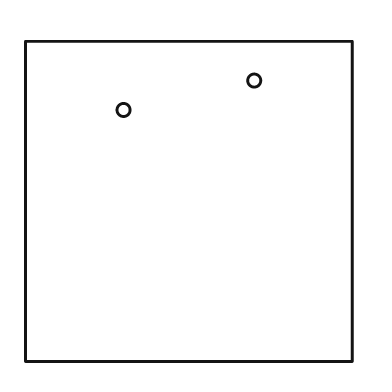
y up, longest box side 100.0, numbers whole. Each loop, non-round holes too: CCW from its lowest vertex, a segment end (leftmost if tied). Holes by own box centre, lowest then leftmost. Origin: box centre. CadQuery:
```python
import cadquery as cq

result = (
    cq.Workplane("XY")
    .moveTo(-50.0, -49.0)
    .lineTo(50.0, -49.0)
    .lineTo(50.0, 49.0)
    .lineTo(-50.0, 49.0)
    .close()
    .moveTo(-20.0, 28.0)
    .circle(2.0)
    .moveTo(20.0, 37.0)
    .circle(2.0)
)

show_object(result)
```